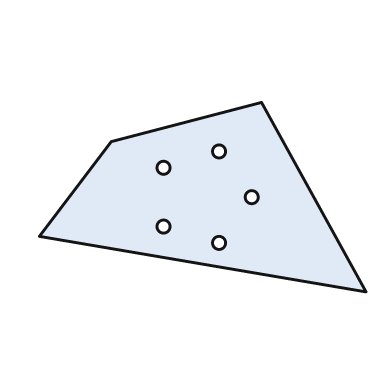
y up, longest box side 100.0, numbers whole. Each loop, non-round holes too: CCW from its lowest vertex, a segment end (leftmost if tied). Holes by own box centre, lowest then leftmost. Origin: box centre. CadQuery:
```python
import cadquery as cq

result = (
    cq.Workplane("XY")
    .moveTo(50.0, -29.0)
    .lineTo(18.0, 29.0)
    .lineTo(-28.0, 17.0)
    .lineTo(-50.0, -12.0)
    .close()
    .moveTo(5.0, -14.0)
    .circle(2.0)
    .moveTo(-12.0, -9.0)
    .circle(2.0)
    .moveTo(15.0, 0.0)
    .circle(2.0)
    .moveTo(-12.0, 9.0)
    .circle(2.0)
    .moveTo(5.0, 14.0)
    .circle(2.0)
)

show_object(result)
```